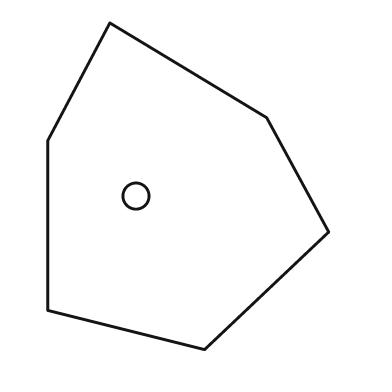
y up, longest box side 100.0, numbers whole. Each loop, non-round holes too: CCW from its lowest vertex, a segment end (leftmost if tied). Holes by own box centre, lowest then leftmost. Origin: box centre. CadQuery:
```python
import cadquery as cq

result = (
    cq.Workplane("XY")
    .moveTo(5.0, -50.0)
    .lineTo(43.0, -14.0)
    .lineTo(24.0, 21.0)
    .lineTo(-24.0, 50.0)
    .lineTo(-43.0, 14.0)
    .lineTo(-43.0, -38.0)
    .close()
    .moveTo(-16.0, -3.0)
    .circle(4.0)
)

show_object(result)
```